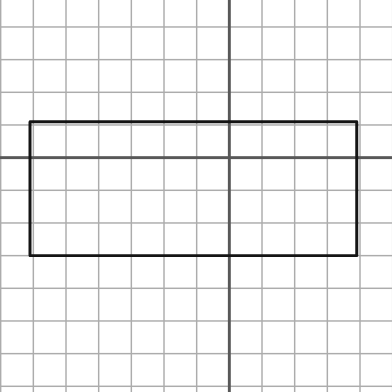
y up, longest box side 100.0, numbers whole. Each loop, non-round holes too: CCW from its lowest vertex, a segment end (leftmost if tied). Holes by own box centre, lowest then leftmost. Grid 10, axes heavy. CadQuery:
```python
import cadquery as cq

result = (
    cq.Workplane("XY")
    .moveTo(-61.0, -30.0)
    .lineTo(39.0, -30.0)
    .lineTo(39.0, 11.0)
    .lineTo(-61.0, 11.0)
    .close()
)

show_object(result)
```